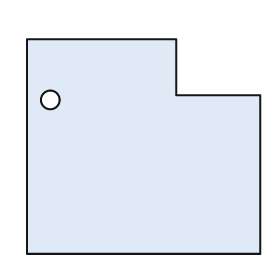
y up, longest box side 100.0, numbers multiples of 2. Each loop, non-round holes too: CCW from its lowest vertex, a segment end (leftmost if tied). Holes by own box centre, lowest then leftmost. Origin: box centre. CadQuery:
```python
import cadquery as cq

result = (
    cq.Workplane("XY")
    .moveTo(-50.0, -46.0)
    .lineTo(50.0, -46.0)
    .lineTo(50.0, 22.0)
    .lineTo(14.0, 22.0)
    .lineTo(14.0, 46.0)
    .lineTo(-50.0, 46.0)
    .close()
    .moveTo(-40.0, 20.0)
    .circle(4.0)
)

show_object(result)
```